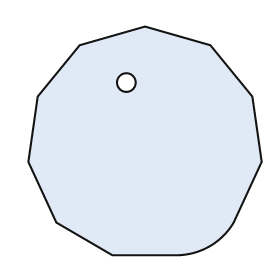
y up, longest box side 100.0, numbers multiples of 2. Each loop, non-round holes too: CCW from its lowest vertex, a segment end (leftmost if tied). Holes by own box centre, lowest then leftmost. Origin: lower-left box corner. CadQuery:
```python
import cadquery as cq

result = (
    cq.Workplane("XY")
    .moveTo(36.0, 0.0)
    .lineTo(64.0, 0.0)
    .threePointArc((78.0, 4.0), (88.0, 14.0))
    .lineTo(100.0, 40.0)
    .lineTo(96.0, 68.0)
    .lineTo(78.0, 90.0)
    .lineTo(50.0, 98.0)
    .lineTo(22.0, 90.0)
    .lineTo(4.0, 68.0)
    .lineTo(0.0, 40.0)
    .lineTo(12.0, 14.0)
    .close()
    .moveTo(42.0, 74.0)
    .circle(4.0)
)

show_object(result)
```